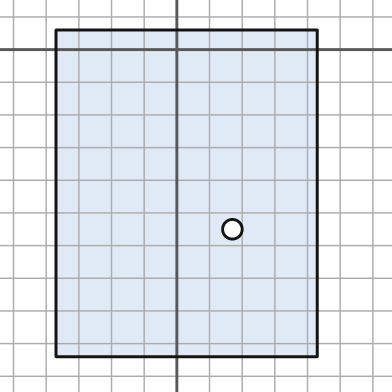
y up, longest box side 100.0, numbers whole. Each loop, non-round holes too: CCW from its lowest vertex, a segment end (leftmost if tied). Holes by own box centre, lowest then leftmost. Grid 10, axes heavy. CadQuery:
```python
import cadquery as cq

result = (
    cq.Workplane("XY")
    .moveTo(-37.0, -94.0)
    .lineTo(43.0, -94.0)
    .lineTo(43.0, 6.0)
    .lineTo(-37.0, 6.0)
    .close()
    .moveTo(17.0, -55.0)
    .circle(3.0)
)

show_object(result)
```